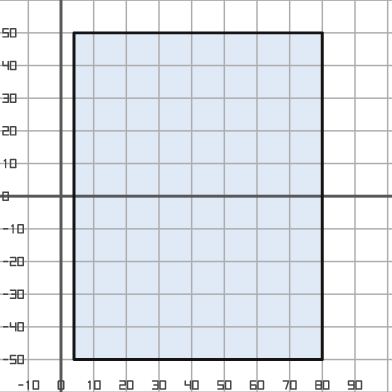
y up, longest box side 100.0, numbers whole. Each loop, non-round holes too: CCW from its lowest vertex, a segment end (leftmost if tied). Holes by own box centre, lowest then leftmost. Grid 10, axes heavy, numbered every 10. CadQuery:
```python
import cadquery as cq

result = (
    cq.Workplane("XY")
    .moveTo(4.0, -50.0)
    .lineTo(80.0, -50.0)
    .lineTo(80.0, 50.0)
    .lineTo(4.0, 50.0)
    .close()
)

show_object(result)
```